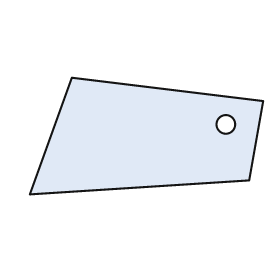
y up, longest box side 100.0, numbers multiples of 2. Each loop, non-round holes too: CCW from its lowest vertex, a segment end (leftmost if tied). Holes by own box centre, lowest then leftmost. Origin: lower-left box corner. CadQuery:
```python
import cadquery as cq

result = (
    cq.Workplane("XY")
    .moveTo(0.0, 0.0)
    .lineTo(94.0, 6.0)
    .lineTo(100.0, 40.0)
    .lineTo(18.0, 50.0)
    .close()
    .moveTo(84.0, 30.0)
    .circle(4.0)
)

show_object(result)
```